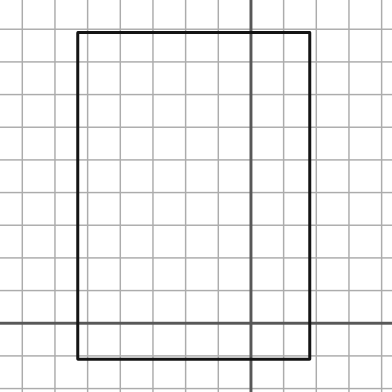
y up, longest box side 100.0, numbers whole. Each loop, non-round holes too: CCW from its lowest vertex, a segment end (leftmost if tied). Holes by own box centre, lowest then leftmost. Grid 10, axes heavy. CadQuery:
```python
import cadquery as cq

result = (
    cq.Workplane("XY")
    .moveTo(-53.0, -11.0)
    .lineTo(18.0, -11.0)
    .lineTo(18.0, 89.0)
    .lineTo(-53.0, 89.0)
    .close()
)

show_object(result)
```